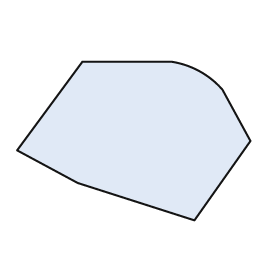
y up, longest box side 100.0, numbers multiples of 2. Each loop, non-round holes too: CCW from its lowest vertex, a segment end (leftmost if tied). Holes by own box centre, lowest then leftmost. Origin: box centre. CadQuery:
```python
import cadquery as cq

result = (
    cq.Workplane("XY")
    .moveTo(26.0, -34.0)
    .lineTo(50.0, 0.0)
    .lineTo(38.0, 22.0)
    .threePointArc((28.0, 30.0), (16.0, 34.0))
    .lineTo(-22.0, 34.0)
    .lineTo(-50.0, -4.0)
    .lineTo(-24.0, -18.0)
    .close()
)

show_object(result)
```